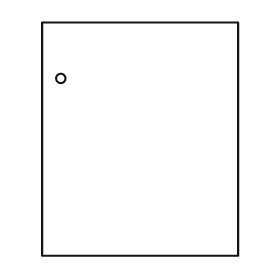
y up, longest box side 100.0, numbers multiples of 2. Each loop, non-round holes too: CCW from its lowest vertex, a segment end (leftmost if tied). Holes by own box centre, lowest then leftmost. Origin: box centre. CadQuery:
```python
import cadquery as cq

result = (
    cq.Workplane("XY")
    .moveTo(-42.0, -50.0)
    .lineTo(42.0, -50.0)
    .lineTo(42.0, 50.0)
    .lineTo(-42.0, 50.0)
    .close()
    .moveTo(-34.0, 26.0)
    .circle(2.0)
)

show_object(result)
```